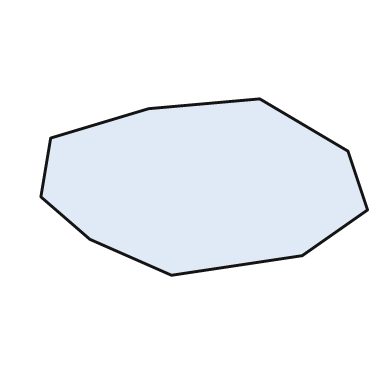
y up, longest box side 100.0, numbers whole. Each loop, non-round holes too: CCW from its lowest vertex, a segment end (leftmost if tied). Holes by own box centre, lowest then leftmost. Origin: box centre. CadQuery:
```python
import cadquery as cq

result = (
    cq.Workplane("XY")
    .moveTo(-10.0, -27.0)
    .lineTo(30.0, -21.0)
    .lineTo(50.0, -7.0)
    .lineTo(44.0, 11.0)
    .lineTo(17.0, 27.0)
    .lineTo(-17.0, 24.0)
    .lineTo(-47.0, 15.0)
    .lineTo(-50.0, -3.0)
    .lineTo(-35.0, -16.0)
    .close()
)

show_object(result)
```